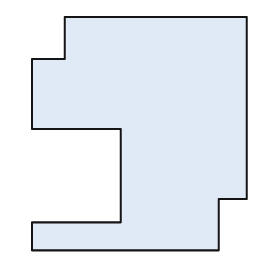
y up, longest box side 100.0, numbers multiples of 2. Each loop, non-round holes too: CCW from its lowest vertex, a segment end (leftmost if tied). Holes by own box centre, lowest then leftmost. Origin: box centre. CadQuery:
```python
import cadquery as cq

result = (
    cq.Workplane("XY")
    .moveTo(-46.0, -50.0)
    .lineTo(34.0, -50.0)
    .lineTo(34.0, -28.0)
    .lineTo(46.0, -28.0)
    .lineTo(46.0, 50.0)
    .lineTo(-32.0, 50.0)
    .lineTo(-32.0, 32.0)
    .lineTo(-46.0, 32.0)
    .lineTo(-46.0, 2.0)
    .lineTo(-8.0, 2.0)
    .lineTo(-8.0, -38.0)
    .lineTo(-46.0, -38.0)
    .close()
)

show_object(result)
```